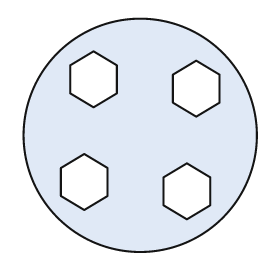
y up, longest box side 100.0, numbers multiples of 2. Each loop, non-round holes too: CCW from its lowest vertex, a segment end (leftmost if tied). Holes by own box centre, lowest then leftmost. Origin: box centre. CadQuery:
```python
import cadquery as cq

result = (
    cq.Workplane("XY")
    .moveTo(0.0, 0.0)
    .circle(50.0)
    .moveTo(20.0, -36.0)
    .lineTo(30.0, -30.0)
    .lineTo(30.0, -18.0)
    .lineTo(20.0, -12.0)
    .lineTo(10.0, -18.0)
    .lineTo(10.0, -30.0)
    .close()
    .moveTo(-24.0, -32.0)
    .lineTo(-14.0, -26.0)
    .lineTo(-14.0, -14.0)
    .lineTo(-24.0, -8.0)
    .lineTo(-34.0, -14.0)
    .lineTo(-34.0, -26.0)
    .close()
    .moveTo(24.0, 8.0)
    .lineTo(34.0, 14.0)
    .lineTo(34.0, 26.0)
    .lineTo(24.0, 32.0)
    .lineTo(14.0, 26.0)
    .lineTo(14.0, 14.0)
    .close()
    .moveTo(-20.0, 12.0)
    .lineTo(-10.0, 18.0)
    .lineTo(-10.0, 30.0)
    .lineTo(-20.0, 36.0)
    .lineTo(-30.0, 30.0)
    .lineTo(-30.0, 18.0)
    .close()
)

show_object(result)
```